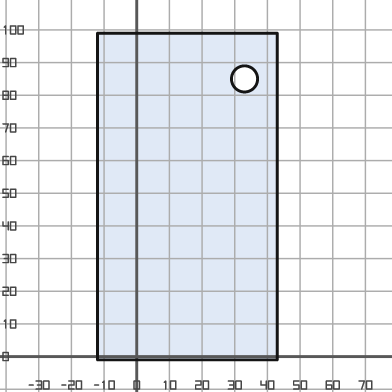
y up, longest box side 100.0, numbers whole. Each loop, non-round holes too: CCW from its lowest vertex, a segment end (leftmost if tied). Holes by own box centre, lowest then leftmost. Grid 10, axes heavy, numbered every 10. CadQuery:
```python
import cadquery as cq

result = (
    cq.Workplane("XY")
    .moveTo(-12.0, -1.0)
    .lineTo(43.0, -1.0)
    .lineTo(43.0, 99.0)
    .lineTo(-12.0, 99.0)
    .close()
    .moveTo(33.0, 85.0)
    .circle(4.0)
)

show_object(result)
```